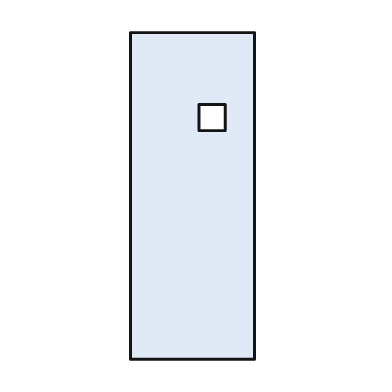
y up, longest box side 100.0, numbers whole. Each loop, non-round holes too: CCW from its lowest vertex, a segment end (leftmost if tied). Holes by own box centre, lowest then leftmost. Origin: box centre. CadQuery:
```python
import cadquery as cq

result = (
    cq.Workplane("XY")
    .moveTo(-19.0, -50.0)
    .lineTo(19.0, -50.0)
    .lineTo(19.0, 50.0)
    .lineTo(-19.0, 50.0)
    .close()
    .moveTo(2.0, 20.0)
    .lineTo(10.0, 20.0)
    .lineTo(10.0, 28.0)
    .lineTo(2.0, 28.0)
    .close()
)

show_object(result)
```